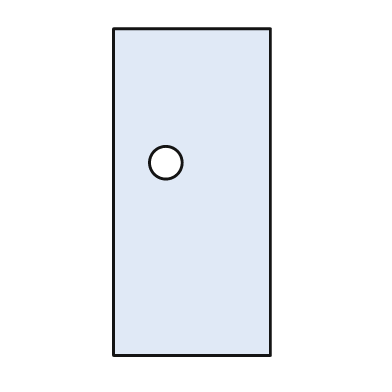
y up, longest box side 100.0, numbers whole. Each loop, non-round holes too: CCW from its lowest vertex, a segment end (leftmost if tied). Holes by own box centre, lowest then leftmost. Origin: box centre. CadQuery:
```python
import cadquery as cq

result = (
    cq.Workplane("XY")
    .moveTo(-24.0, -50.0)
    .lineTo(24.0, -50.0)
    .lineTo(24.0, 50.0)
    .lineTo(-24.0, 50.0)
    .close()
    .moveTo(-8.0, 9.0)
    .circle(5.0)
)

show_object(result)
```